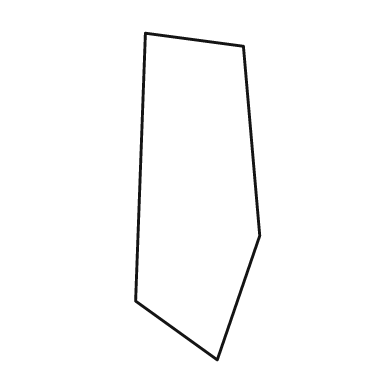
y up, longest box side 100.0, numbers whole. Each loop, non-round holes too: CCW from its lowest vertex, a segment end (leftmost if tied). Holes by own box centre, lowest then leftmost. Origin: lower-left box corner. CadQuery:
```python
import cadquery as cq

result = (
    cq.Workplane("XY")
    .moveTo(25.0, 0.0)
    .lineTo(38.0, 38.0)
    .lineTo(33.0, 96.0)
    .lineTo(3.0, 100.0)
    .lineTo(0.0, 18.0)
    .close()
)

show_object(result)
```